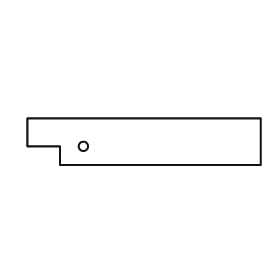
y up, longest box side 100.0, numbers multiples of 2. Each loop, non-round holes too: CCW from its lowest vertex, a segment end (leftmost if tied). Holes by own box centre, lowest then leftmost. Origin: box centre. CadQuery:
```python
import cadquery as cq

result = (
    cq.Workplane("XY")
    .moveTo(-36.0, -10.0)
    .lineTo(50.0, -10.0)
    .lineTo(50.0, 10.0)
    .lineTo(-50.0, 10.0)
    .lineTo(-50.0, -2.0)
    .lineTo(-36.0, -2.0)
    .close()
    .moveTo(-26.0, -2.0)
    .circle(2.0)
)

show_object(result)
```